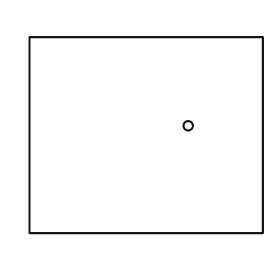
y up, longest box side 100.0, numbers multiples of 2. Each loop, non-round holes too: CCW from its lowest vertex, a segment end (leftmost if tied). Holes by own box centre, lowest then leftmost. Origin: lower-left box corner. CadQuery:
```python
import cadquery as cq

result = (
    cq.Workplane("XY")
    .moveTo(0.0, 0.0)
    .lineTo(100.0, 0.0)
    .lineTo(100.0, 84.0)
    .lineTo(0.0, 84.0)
    .close()
    .moveTo(68.0, 46.0)
    .circle(2.0)
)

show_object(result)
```